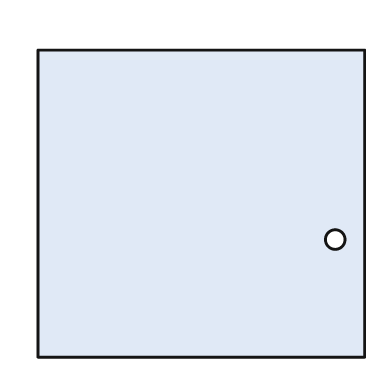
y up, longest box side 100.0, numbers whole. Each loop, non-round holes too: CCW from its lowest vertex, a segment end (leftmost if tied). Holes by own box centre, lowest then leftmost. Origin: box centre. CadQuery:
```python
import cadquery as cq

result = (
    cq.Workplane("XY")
    .moveTo(-50.0, -47.0)
    .lineTo(50.0, -47.0)
    .lineTo(50.0, 47.0)
    .lineTo(-50.0, 47.0)
    .close()
    .moveTo(41.0, -11.0)
    .circle(3.0)
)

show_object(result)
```